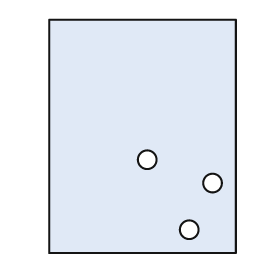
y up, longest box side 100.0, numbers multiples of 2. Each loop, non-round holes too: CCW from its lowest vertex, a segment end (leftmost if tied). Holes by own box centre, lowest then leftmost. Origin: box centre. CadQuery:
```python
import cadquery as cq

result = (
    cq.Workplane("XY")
    .moveTo(-40.0, -50.0)
    .lineTo(40.0, -50.0)
    .lineTo(40.0, 50.0)
    .lineTo(-40.0, 50.0)
    .close()
    .moveTo(20.0, -40.0)
    .circle(4.0)
    .moveTo(30.0, -20.0)
    .circle(4.0)
    .moveTo(2.0, -10.0)
    .circle(4.0)
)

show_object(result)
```